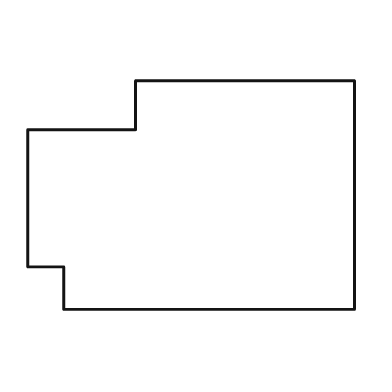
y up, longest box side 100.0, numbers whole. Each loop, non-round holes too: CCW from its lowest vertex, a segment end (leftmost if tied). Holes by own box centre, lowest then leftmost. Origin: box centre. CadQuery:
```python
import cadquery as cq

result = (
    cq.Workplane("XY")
    .moveTo(-39.0, -35.0)
    .lineTo(50.0, -35.0)
    .lineTo(50.0, 35.0)
    .lineTo(-17.0, 35.0)
    .lineTo(-17.0, 20.0)
    .lineTo(-50.0, 20.0)
    .lineTo(-50.0, -22.0)
    .lineTo(-39.0, -22.0)
    .close()
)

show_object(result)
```